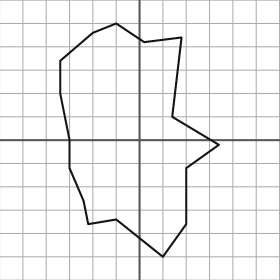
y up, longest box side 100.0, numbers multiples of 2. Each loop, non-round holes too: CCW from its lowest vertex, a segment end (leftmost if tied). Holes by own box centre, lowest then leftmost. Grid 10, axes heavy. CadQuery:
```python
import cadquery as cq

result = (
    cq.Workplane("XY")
    .moveTo(10.0, -50.0)
    .lineTo(20.0, -36.0)
    .lineTo(20.0, -12.0)
    .lineTo(34.0, -2.0)
    .lineTo(14.0, 10.0)
    .lineTo(18.0, 44.0)
    .lineTo(2.0, 42.0)
    .lineTo(-10.0, 50.0)
    .lineTo(-20.0, 46.0)
    .lineTo(-34.0, 34.0)
    .lineTo(-34.0, 20.0)
    .lineTo(-30.0, 0.0)
    .lineTo(-30.0, -12.0)
    .lineTo(-24.0, -26.0)
    .lineTo(-22.0, -36.0)
    .lineTo(-10.0, -34.0)
    .close()
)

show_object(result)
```